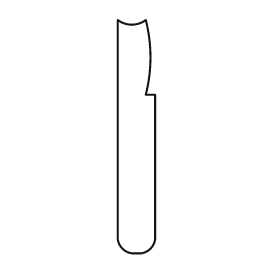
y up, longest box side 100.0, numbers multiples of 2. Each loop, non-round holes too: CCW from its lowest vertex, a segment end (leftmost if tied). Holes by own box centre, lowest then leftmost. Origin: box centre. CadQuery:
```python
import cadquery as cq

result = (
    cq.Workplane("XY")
    .moveTo(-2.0, -50.0)
    .lineTo(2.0, -50.0)
    .threePointArc((6.0, -48.0), (8.0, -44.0))
    .lineTo(8.0, 18.0)
    .lineTo(4.0, 18.0)
    .threePointArc((6.0, 34.0), (4.0, 50.0))
    .threePointArc((-2.0, 48.0), (-8.0, 50.0))
    .lineTo(-8.0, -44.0)
    .threePointArc((-6.0, -48.0), (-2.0, -50.0))
    .close()
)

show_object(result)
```